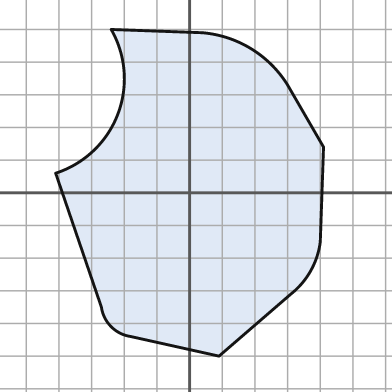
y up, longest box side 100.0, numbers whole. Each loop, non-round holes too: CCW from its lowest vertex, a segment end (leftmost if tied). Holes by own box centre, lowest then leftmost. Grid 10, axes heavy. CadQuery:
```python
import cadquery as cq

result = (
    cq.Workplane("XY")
    .moveTo(9.0, -50.0)
    .lineTo(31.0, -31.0)
    .threePointArc((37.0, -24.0), (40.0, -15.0))
    .lineTo(41.0, 14.0)
    .lineTo(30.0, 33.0)
    .threePointArc((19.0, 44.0), (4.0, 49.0))
    .lineTo(-24.0, 50.0)
    .threePointArc((-22.0, 24.0), (-41.0, 6.0))
    .lineTo(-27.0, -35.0)
    .threePointArc((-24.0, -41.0), (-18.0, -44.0))
    .close()
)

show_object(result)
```